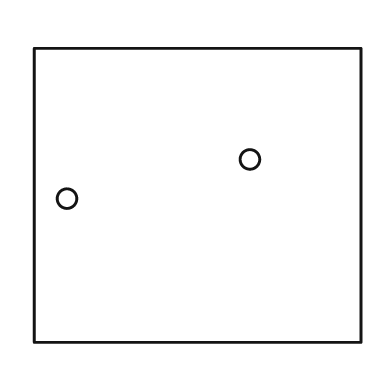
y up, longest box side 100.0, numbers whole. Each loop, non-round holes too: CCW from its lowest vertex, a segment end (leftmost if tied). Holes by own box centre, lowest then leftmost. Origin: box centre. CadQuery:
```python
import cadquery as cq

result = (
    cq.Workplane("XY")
    .moveTo(-50.0, -45.0)
    .lineTo(50.0, -45.0)
    .lineTo(50.0, 45.0)
    .lineTo(-50.0, 45.0)
    .close()
    .moveTo(-40.0, -1.0)
    .circle(3.0)
    .moveTo(16.0, 11.0)
    .circle(3.0)
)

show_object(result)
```